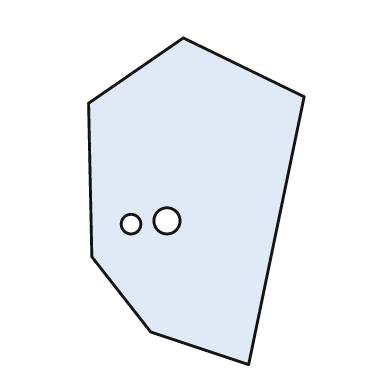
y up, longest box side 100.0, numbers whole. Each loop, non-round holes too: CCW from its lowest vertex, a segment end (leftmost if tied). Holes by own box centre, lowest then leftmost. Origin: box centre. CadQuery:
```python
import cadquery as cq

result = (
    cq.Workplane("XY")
    .moveTo(16.0, -50.0)
    .lineTo(33.0, 32.0)
    .lineTo(-4.0, 50.0)
    .lineTo(-33.0, 30.0)
    .lineTo(-32.0, -17.0)
    .lineTo(-14.0, -40.0)
    .close()
    .moveTo(-20.0, -7.0)
    .circle(3.0)
    .moveTo(-9.0, -6.0)
    .circle(4.0)
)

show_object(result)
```